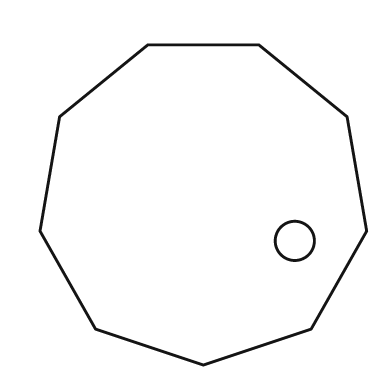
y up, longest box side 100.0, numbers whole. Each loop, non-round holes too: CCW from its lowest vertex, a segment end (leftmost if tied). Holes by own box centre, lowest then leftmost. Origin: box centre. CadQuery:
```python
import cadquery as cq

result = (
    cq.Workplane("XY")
    .moveTo(0.0, -49.0)
    .lineTo(33.0, -38.0)
    .lineTo(50.0, -8.0)
    .lineTo(44.0, 27.0)
    .lineTo(17.0, 49.0)
    .lineTo(-17.0, 49.0)
    .lineTo(-44.0, 27.0)
    .lineTo(-50.0, -8.0)
    .lineTo(-33.0, -38.0)
    .close()
    .moveTo(28.0, -11.0)
    .circle(6.0)
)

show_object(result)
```